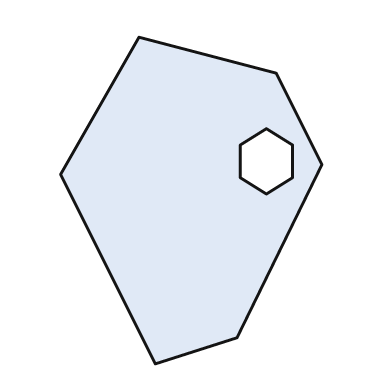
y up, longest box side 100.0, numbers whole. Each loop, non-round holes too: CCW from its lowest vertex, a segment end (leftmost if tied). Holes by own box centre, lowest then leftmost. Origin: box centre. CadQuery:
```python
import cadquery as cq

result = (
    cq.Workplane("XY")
    .moveTo(-11.0, -50.0)
    .lineTo(14.0, -42.0)
    .lineTo(40.0, 11.0)
    .lineTo(26.0, 39.0)
    .lineTo(-16.0, 50.0)
    .lineTo(-40.0, 8.0)
    .close()
    .moveTo(23.0, 2.0)
    .lineTo(31.0, 7.0)
    .lineTo(31.0, 17.0)
    .lineTo(23.0, 22.0)
    .lineTo(15.0, 17.0)
    .lineTo(15.0, 7.0)
    .close()
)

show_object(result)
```